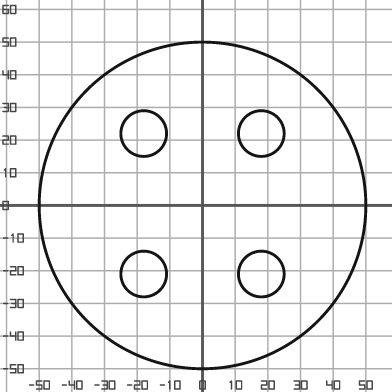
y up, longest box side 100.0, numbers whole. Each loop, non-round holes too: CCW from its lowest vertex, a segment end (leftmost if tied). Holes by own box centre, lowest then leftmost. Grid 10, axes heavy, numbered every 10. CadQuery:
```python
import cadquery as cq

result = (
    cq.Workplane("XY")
    .moveTo(0.0, 0.0)
    .circle(50.0)
    .moveTo(-18.0, -21.0)
    .circle(7.0)
    .moveTo(18.0, -21.0)
    .circle(7.0)
    .moveTo(-18.0, 22.0)
    .circle(7.0)
    .moveTo(18.0, 22.0)
    .circle(7.0)
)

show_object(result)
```